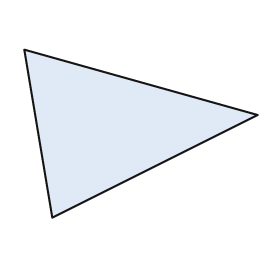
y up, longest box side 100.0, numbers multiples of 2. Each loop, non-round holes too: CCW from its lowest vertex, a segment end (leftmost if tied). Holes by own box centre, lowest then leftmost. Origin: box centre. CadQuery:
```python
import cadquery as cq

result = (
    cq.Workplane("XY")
    .moveTo(-38.0, -36.0)
    .lineTo(50.0, 8.0)
    .lineTo(-50.0, 36.0)
    .close()
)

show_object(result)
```